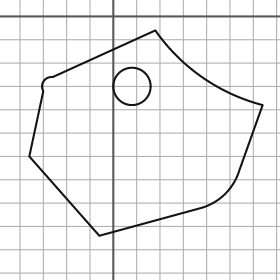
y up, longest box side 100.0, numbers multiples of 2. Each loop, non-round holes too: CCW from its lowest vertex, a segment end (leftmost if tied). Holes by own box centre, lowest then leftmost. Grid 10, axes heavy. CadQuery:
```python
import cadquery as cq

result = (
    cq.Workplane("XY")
    .moveTo(-6.0, -94.0)
    .lineTo(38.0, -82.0)
    .threePointArc((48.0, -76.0), (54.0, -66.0))
    .lineTo(64.0, -38.0)
    .threePointArc((38.0, -26.0), (18.0, -6.0))
    .lineTo(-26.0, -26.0)
    .threePointArc((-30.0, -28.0), (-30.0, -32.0))
    .lineTo(-36.0, -60.0)
    .close()
    .moveTo(8.0, -30.0)
    .circle(8.0)
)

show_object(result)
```